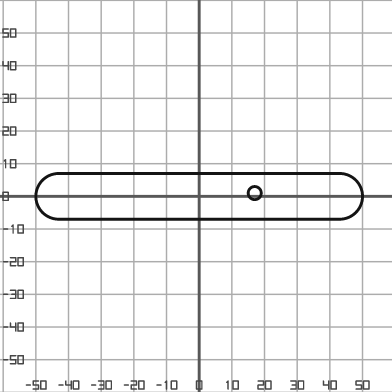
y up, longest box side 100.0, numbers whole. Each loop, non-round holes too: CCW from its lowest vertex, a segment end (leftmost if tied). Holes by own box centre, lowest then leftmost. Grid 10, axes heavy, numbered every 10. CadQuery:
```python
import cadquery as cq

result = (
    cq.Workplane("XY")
    .moveTo(-43.0, -7.0)
    .lineTo(43.0, -7.0)
    .threePointArc((50.0, 0.0), (43.0, 7.0))
    .lineTo(-43.0, 7.0)
    .threePointArc((-50.0, 0.0), (-43.0, -7.0))
    .close()
    .moveTo(17.0, 1.0)
    .circle(2.0)
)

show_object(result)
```